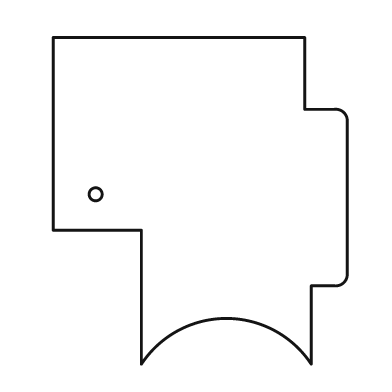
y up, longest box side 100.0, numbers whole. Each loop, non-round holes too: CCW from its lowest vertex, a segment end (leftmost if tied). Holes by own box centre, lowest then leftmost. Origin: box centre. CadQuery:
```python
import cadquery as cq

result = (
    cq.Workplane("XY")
    .moveTo(-18.0, -50.0)
    .threePointArc((8.0, -36.0), (34.0, -50.0))
    .lineTo(34.0, -26.0)
    .lineTo(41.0, -26.0)
    .threePointArc((44.0, -25.0), (45.0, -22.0))
    .lineTo(45.0, 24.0)
    .threePointArc((44.0, 27.0), (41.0, 28.0))
    .lineTo(32.0, 28.0)
    .lineTo(32.0, 50.0)
    .lineTo(-45.0, 50.0)
    .lineTo(-45.0, -9.0)
    .lineTo(-18.0, -9.0)
    .close()
    .moveTo(-32.0, 2.0)
    .circle(2.0)
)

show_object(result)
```